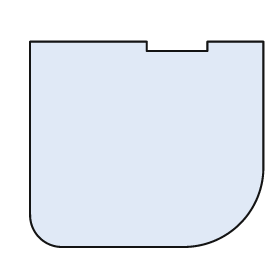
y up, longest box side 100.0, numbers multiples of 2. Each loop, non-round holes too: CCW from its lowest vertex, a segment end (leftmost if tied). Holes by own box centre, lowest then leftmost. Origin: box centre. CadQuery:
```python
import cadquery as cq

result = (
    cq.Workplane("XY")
    .moveTo(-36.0, -44.0)
    .lineTo(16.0, -44.0)
    .threePointArc((40.0, -34.0), (50.0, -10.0))
    .lineTo(50.0, 44.0)
    .lineTo(26.0, 44.0)
    .lineTo(26.0, 40.0)
    .lineTo(0.0, 40.0)
    .lineTo(0.0, 44.0)
    .lineTo(-50.0, 44.0)
    .lineTo(-50.0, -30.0)
    .threePointArc((-46.0, -40.0), (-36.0, -44.0))
    .close()
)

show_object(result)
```